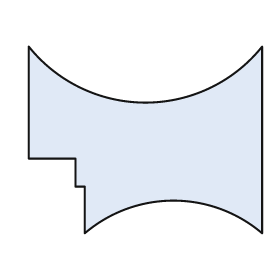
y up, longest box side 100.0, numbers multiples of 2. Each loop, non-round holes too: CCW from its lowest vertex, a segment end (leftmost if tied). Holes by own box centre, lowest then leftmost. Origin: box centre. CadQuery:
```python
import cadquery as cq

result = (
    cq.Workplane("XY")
    .moveTo(-26.0, -40.0)
    .threePointArc((12.0, -26.0), (50.0, -40.0))
    .lineTo(50.0, 40.0)
    .threePointArc((0.0, 16.0), (-50.0, 40.0))
    .lineTo(-50.0, -8.0)
    .lineTo(-30.0, -8.0)
    .lineTo(-30.0, -20.0)
    .lineTo(-26.0, -20.0)
    .close()
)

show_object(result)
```